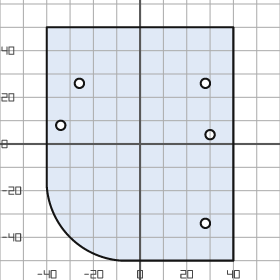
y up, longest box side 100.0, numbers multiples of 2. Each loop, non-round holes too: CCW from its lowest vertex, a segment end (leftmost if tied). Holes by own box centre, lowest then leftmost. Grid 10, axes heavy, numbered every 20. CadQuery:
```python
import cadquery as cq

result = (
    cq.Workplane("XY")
    .moveTo(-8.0, -50.0)
    .lineTo(40.0, -50.0)
    .lineTo(40.0, 50.0)
    .lineTo(-40.0, 50.0)
    .lineTo(-40.0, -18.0)
    .threePointArc((-30.0, -40.0), (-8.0, -50.0))
    .close()
    .moveTo(28.0, -34.0)
    .circle(2.0)
    .moveTo(30.0, 4.0)
    .circle(2.0)
    .moveTo(-34.0, 8.0)
    .circle(2.0)
    .moveTo(-26.0, 26.0)
    .circle(2.0)
    .moveTo(28.0, 26.0)
    .circle(2.0)
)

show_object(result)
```